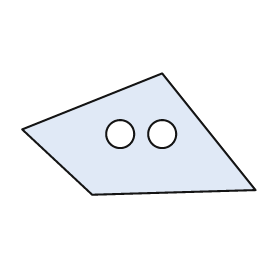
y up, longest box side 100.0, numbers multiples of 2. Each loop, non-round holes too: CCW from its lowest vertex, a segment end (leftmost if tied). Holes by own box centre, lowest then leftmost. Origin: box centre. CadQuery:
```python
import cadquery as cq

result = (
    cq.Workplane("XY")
    .moveTo(-20.0, -26.0)
    .lineTo(50.0, -24.0)
    .lineTo(10.0, 26.0)
    .lineTo(-50.0, 2.0)
    .close()
    .moveTo(-8.0, 0.0)
    .circle(6.0)
    .moveTo(10.0, 0.0)
    .circle(6.0)
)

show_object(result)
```